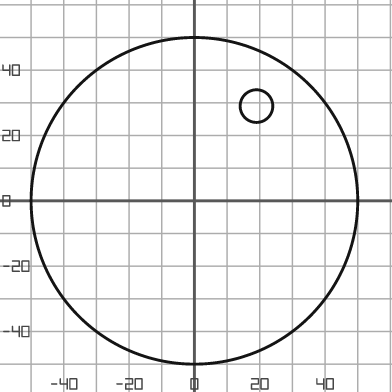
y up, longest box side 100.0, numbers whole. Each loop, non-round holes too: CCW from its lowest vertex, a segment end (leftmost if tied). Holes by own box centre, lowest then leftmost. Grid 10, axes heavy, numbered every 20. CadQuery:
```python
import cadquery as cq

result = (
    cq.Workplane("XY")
    .moveTo(0.0, 0.0)
    .circle(50.0)
    .moveTo(19.0, 29.0)
    .circle(5.0)
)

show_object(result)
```